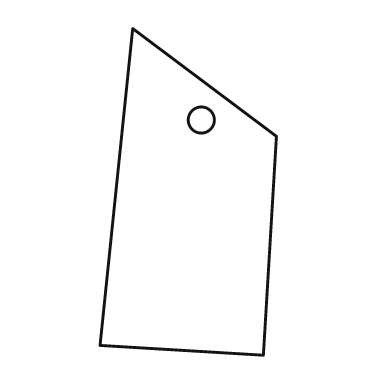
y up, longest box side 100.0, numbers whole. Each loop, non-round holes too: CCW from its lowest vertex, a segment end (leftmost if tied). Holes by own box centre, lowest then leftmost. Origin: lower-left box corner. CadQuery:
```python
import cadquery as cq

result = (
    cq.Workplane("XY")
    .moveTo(50.0, 0.0)
    .lineTo(54.0, 67.0)
    .lineTo(10.0, 100.0)
    .lineTo(0.0, 3.0)
    .close()
    .moveTo(31.0, 72.0)
    .circle(4.0)
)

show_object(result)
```